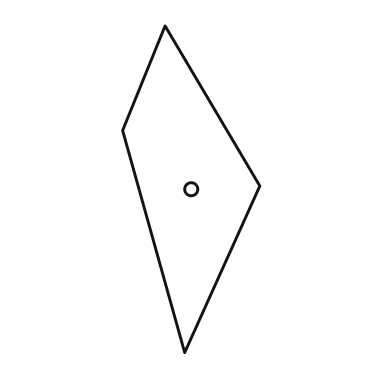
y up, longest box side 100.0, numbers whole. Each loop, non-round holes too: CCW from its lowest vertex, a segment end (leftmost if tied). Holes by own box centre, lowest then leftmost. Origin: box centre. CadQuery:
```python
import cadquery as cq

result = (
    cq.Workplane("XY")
    .moveTo(-2.0, -50.0)
    .lineTo(21.0, 1.0)
    .lineTo(-8.0, 50.0)
    .lineTo(-21.0, 18.0)
    .close()
    .moveTo(0.0, 0.0)
    .circle(2.0)
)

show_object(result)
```